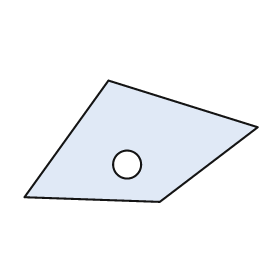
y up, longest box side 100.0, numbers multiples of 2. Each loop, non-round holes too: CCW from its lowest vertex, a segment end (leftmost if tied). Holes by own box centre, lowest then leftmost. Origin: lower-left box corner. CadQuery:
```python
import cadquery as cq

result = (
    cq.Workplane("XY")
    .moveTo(58.0, 0.0)
    .lineTo(100.0, 32.0)
    .lineTo(36.0, 52.0)
    .lineTo(0.0, 2.0)
    .close()
    .moveTo(44.0, 16.0)
    .circle(6.0)
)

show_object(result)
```